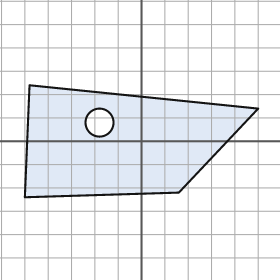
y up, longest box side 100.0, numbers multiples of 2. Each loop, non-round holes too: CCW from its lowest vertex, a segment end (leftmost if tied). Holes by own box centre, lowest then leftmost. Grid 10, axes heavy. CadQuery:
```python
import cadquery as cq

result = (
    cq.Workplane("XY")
    .moveTo(-50.0, -24.0)
    .lineTo(16.0, -22.0)
    .lineTo(50.0, 14.0)
    .lineTo(-48.0, 24.0)
    .close()
    .moveTo(-18.0, 8.0)
    .circle(6.0)
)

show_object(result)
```